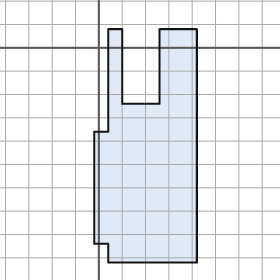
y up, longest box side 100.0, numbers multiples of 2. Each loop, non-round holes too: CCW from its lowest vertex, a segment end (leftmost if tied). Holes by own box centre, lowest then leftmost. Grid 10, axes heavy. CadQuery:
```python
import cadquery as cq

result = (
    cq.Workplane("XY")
    .moveTo(4.0, -92.0)
    .lineTo(42.0, -92.0)
    .lineTo(42.0, 8.0)
    .lineTo(26.0, 8.0)
    .lineTo(26.0, -24.0)
    .lineTo(10.0, -24.0)
    .lineTo(10.0, 8.0)
    .lineTo(4.0, 8.0)
    .lineTo(4.0, -36.0)
    .lineTo(-2.0, -36.0)
    .lineTo(-2.0, -84.0)
    .lineTo(4.0, -84.0)
    .close()
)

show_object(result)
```